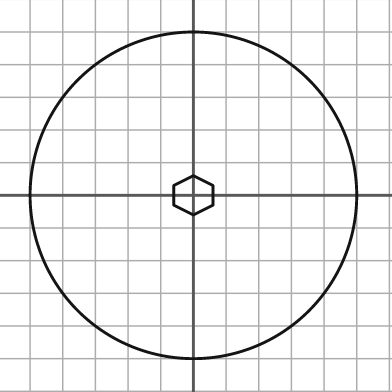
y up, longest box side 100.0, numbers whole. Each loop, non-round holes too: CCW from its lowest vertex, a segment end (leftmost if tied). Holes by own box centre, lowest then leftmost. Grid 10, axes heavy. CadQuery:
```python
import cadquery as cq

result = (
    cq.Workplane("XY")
    .moveTo(0.0, 0.0)
    .circle(50.0)
    .moveTo(0.0, -6.0)
    .lineTo(6.0, -3.0)
    .lineTo(6.0, 3.0)
    .lineTo(0.0, 6.0)
    .lineTo(-6.0, 3.0)
    .lineTo(-6.0, -3.0)
    .close()
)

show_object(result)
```